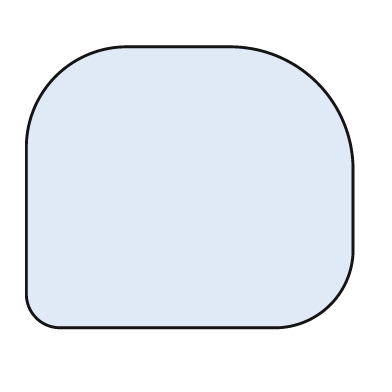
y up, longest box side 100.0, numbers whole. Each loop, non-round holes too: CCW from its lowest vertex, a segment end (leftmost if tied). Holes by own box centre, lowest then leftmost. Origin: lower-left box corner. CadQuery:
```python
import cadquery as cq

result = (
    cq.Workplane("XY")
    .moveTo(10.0, 0.0)
    .lineTo(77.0, 0.0)
    .threePointArc((93.0, 7.0), (100.0, 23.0))
    .lineTo(100.0, 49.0)
    .threePointArc((89.0, 75.0), (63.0, 86.0))
    .lineTo(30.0, 86.0)
    .threePointArc((9.0, 77.0), (0.0, 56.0))
    .lineTo(0.0, 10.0)
    .threePointArc((3.0, 3.0), (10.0, 0.0))
    .close()
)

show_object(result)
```